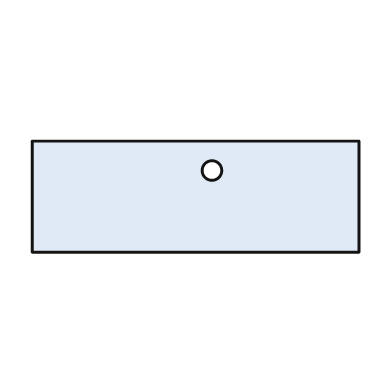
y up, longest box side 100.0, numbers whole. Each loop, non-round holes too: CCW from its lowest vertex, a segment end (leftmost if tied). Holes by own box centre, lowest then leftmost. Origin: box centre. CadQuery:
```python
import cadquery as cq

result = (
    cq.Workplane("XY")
    .moveTo(-50.0, -17.0)
    .lineTo(50.0, -17.0)
    .lineTo(50.0, 17.0)
    .lineTo(-50.0, 17.0)
    .close()
    .moveTo(5.0, 8.0)
    .circle(3.0)
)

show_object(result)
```